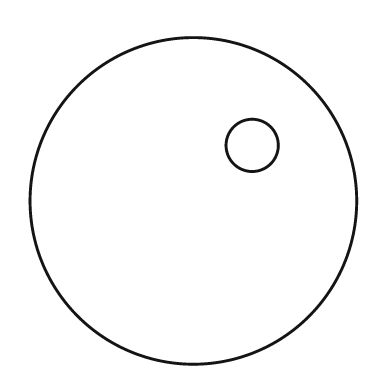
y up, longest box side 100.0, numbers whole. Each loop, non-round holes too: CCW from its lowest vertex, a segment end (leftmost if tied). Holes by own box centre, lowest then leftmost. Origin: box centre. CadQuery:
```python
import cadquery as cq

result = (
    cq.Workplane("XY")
    .moveTo(0.0, 0.0)
    .circle(50.0)
    .moveTo(18.0, 17.0)
    .circle(8.0)
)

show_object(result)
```